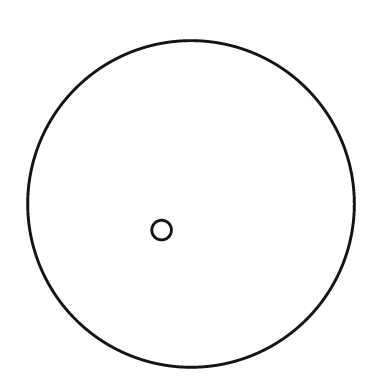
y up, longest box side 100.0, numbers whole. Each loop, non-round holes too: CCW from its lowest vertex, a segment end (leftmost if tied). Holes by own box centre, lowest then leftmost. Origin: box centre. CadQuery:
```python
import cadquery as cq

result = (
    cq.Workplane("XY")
    .moveTo(0.0, 0.0)
    .circle(50.0)
    .moveTo(-9.0, -8.0)
    .circle(3.0)
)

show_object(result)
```